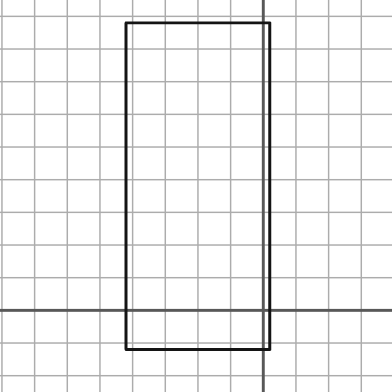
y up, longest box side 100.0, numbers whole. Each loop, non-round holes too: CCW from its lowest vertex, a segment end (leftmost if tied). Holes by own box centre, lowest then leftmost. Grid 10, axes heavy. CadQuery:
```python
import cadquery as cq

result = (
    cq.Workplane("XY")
    .moveTo(-42.0, -12.0)
    .lineTo(2.0, -12.0)
    .lineTo(2.0, 88.0)
    .lineTo(-42.0, 88.0)
    .close()
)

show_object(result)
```